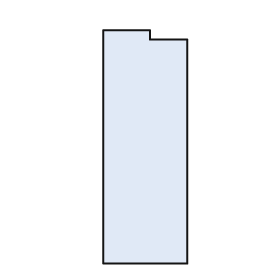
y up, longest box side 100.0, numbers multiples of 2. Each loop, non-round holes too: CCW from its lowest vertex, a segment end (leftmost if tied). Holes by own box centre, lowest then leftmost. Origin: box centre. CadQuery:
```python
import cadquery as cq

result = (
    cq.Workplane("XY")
    .moveTo(-18.0, -50.0)
    .lineTo(18.0, -50.0)
    .lineTo(18.0, 46.0)
    .lineTo(2.0, 46.0)
    .lineTo(2.0, 50.0)
    .lineTo(-18.0, 50.0)
    .close()
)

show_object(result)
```